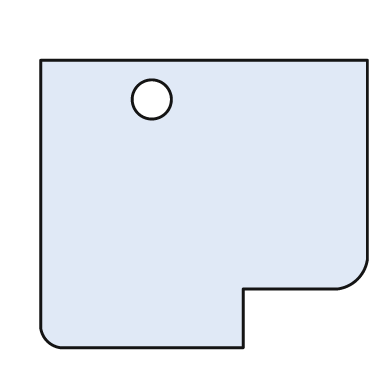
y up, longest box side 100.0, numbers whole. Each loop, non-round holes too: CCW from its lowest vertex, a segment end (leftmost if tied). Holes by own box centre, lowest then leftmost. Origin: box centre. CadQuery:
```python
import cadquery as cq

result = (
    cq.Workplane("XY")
    .moveTo(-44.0, -44.0)
    .lineTo(12.0, -44.0)
    .lineTo(12.0, -26.0)
    .lineTo(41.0, -26.0)
    .threePointArc((47.0, -23.0), (50.0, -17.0))
    .lineTo(50.0, 44.0)
    .lineTo(-50.0, 44.0)
    .lineTo(-50.0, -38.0)
    .threePointArc((-48.0, -42.0), (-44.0, -44.0))
    .close()
    .moveTo(-16.0, 32.0)
    .circle(6.0)
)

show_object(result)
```